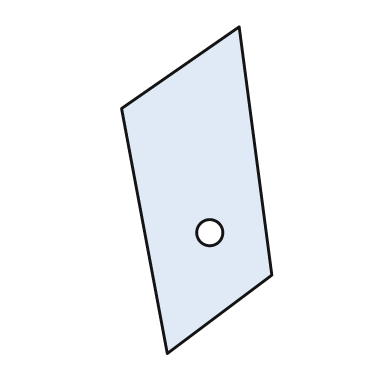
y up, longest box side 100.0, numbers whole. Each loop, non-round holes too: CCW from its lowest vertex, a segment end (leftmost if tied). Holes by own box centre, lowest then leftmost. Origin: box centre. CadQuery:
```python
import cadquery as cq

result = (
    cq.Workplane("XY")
    .moveTo(-9.0, -50.0)
    .lineTo(23.0, -26.0)
    .lineTo(13.0, 50.0)
    .lineTo(-23.0, 25.0)
    .close()
    .moveTo(4.0, -13.0)
    .circle(4.0)
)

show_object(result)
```